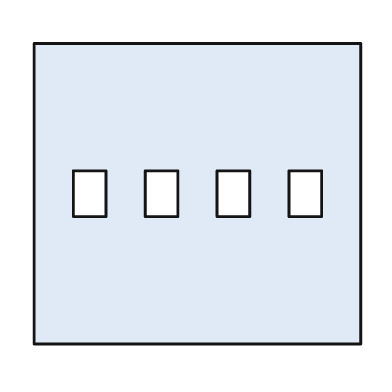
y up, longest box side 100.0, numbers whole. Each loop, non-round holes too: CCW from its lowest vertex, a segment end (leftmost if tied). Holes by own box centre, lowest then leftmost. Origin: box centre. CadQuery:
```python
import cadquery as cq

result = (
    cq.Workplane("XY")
    .moveTo(-50.0, -46.0)
    .lineTo(50.0, -46.0)
    .lineTo(50.0, 46.0)
    .lineTo(-50.0, 46.0)
    .close()
    .moveTo(-38.0, -7.0)
    .lineTo(-28.0, -7.0)
    .lineTo(-28.0, 7.0)
    .lineTo(-38.0, 7.0)
    .close()
    .moveTo(-16.0, -7.0)
    .lineTo(-6.0, -7.0)
    .lineTo(-6.0, 7.0)
    .lineTo(-16.0, 7.0)
    .close()
    .moveTo(6.0, -7.0)
    .lineTo(16.0, -7.0)
    .lineTo(16.0, 7.0)
    .lineTo(6.0, 7.0)
    .close()
    .moveTo(28.0, -7.0)
    .lineTo(38.0, -7.0)
    .lineTo(38.0, 7.0)
    .lineTo(28.0, 7.0)
    .close()
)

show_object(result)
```